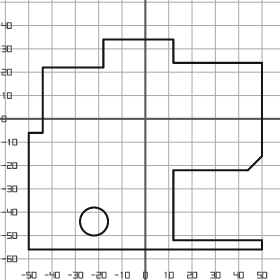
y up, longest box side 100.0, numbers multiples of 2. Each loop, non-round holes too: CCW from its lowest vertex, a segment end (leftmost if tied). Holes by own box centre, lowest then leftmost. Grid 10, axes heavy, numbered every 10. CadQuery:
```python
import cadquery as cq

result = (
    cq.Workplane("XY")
    .moveTo(-50.0, -56.0)
    .lineTo(50.0, -56.0)
    .lineTo(50.0, -52.0)
    .lineTo(12.0, -52.0)
    .lineTo(12.0, -22.0)
    .lineTo(44.0, -22.0)
    .lineTo(50.0, -16.0)
    .lineTo(50.0, 24.0)
    .lineTo(12.0, 24.0)
    .lineTo(12.0, 34.0)
    .lineTo(-18.0, 34.0)
    .lineTo(-18.0, 22.0)
    .lineTo(-44.0, 22.0)
    .lineTo(-44.0, -6.0)
    .lineTo(-50.0, -6.0)
    .close()
    .moveTo(-22.0, -44.0)
    .circle(6.0)
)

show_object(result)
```